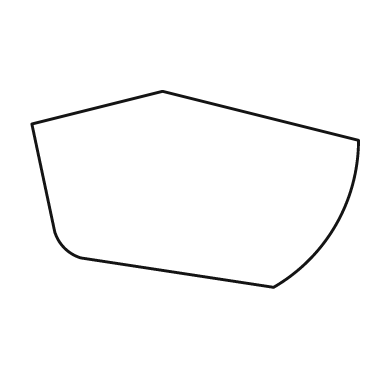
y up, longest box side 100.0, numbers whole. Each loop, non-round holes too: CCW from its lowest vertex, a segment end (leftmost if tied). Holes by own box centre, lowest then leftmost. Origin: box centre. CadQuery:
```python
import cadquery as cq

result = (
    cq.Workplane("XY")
    .moveTo(24.0, -30.0)
    .threePointArc((43.0, -11.0), (50.0, 15.0))
    .lineTo(-10.0, 30.0)
    .lineTo(-50.0, 20.0)
    .lineTo(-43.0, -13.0)
    .threePointArc((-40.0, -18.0), (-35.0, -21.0))
    .close()
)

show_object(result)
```